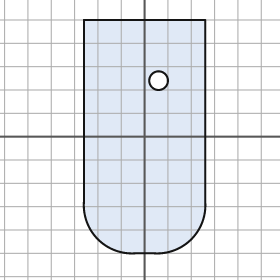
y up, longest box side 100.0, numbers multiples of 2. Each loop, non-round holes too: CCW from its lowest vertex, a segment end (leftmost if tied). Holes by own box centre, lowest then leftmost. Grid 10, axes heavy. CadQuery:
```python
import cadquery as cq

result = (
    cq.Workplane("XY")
    .moveTo(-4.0, -50.0)
    .lineTo(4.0, -50.0)
    .threePointArc((20.0, -44.0), (26.0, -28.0))
    .lineTo(26.0, 50.0)
    .lineTo(-26.0, 50.0)
    .lineTo(-26.0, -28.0)
    .threePointArc((-20.0, -44.0), (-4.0, -50.0))
    .close()
    .moveTo(6.0, 24.0)
    .circle(4.0)
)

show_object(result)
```